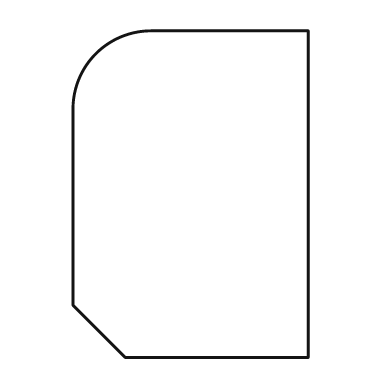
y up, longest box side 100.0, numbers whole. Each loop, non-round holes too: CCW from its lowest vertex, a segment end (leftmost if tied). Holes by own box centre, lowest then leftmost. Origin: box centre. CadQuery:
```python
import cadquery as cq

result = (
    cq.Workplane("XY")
    .moveTo(-20.0, -50.0)
    .lineTo(36.0, -50.0)
    .lineTo(36.0, 50.0)
    .lineTo(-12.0, 50.0)
    .threePointArc((-29.0, 43.0), (-36.0, 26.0))
    .lineTo(-36.0, -34.0)
    .close()
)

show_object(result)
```